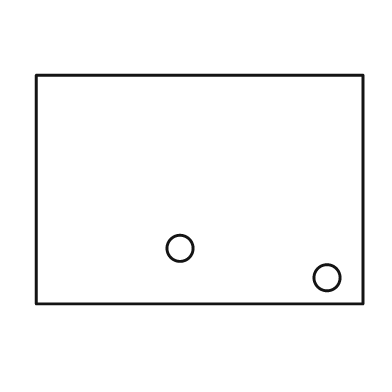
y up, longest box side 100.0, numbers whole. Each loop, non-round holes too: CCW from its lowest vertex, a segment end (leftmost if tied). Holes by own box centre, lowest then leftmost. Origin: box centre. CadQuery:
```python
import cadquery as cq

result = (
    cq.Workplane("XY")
    .moveTo(-50.0, -35.0)
    .lineTo(50.0, -35.0)
    .lineTo(50.0, 35.0)
    .lineTo(-50.0, 35.0)
    .close()
    .moveTo(39.0, -27.0)
    .circle(4.0)
    .moveTo(-6.0, -18.0)
    .circle(4.0)
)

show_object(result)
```